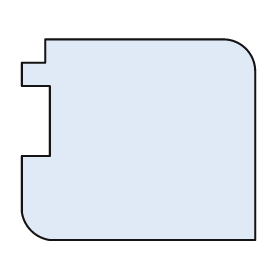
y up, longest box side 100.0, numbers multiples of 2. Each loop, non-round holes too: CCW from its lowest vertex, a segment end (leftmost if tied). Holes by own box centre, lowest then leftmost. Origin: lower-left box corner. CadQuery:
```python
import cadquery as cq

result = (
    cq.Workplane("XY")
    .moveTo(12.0, 0.0)
    .lineTo(100.0, 0.0)
    .lineTo(100.0, 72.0)
    .threePointArc((96.0, 82.0), (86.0, 86.0))
    .lineTo(10.0, 86.0)
    .lineTo(10.0, 76.0)
    .lineTo(0.0, 76.0)
    .lineTo(0.0, 66.0)
    .lineTo(12.0, 66.0)
    .lineTo(12.0, 36.0)
    .lineTo(0.0, 36.0)
    .lineTo(0.0, 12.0)
    .threePointArc((4.0, 4.0), (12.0, 0.0))
    .close()
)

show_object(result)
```